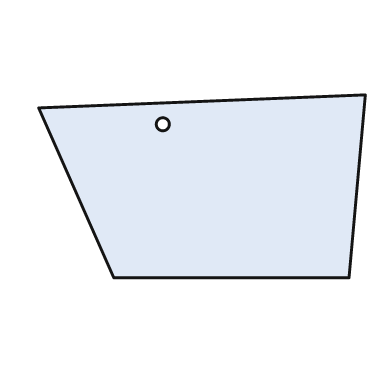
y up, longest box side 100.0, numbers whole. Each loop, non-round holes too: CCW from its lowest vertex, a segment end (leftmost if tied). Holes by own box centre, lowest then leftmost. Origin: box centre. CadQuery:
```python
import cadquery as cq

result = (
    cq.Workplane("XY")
    .moveTo(-27.0, -28.0)
    .lineTo(45.0, -28.0)
    .lineTo(50.0, 28.0)
    .lineTo(-50.0, 24.0)
    .close()
    .moveTo(-12.0, 19.0)
    .circle(2.0)
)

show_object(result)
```